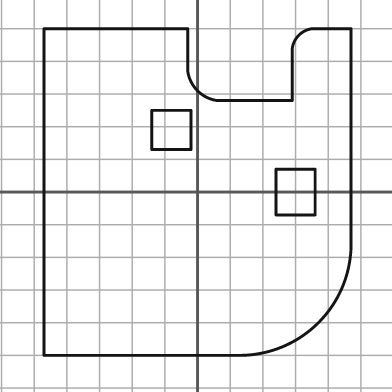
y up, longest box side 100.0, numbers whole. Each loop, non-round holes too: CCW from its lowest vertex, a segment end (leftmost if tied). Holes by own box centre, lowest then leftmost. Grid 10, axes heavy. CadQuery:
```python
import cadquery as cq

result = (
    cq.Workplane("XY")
    .moveTo(-47.0, -50.0)
    .lineTo(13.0, -50.0)
    .threePointArc((37.0, -40.0), (47.0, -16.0))
    .lineTo(47.0, 50.0)
    .lineTo(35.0, 50.0)
    .threePointArc((31.0, 48.0), (29.0, 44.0))
    .lineTo(29.0, 28.0)
    .lineTo(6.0, 28.0)
    .threePointArc((0.0, 31.0), (-3.0, 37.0))
    .lineTo(-3.0, 50.0)
    .lineTo(-47.0, 50.0)
    .close()
    .moveTo(24.0, -7.0)
    .lineTo(36.0, -7.0)
    .lineTo(36.0, 7.0)
    .lineTo(24.0, 7.0)
    .close()
    .moveTo(-14.0, 13.0)
    .lineTo(-2.0, 13.0)
    .lineTo(-2.0, 25.0)
    .lineTo(-14.0, 25.0)
    .close()
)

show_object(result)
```